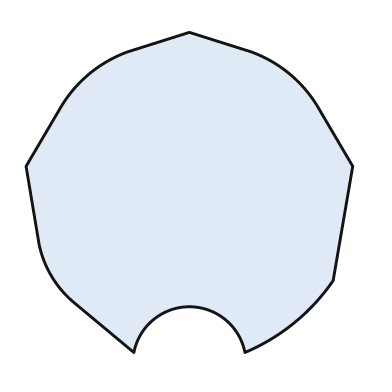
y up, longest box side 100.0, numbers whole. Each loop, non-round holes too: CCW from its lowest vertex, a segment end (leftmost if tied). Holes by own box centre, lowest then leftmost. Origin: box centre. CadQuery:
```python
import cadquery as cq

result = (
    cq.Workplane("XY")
    .moveTo(-17.0, -49.0)
    .threePointArc((0.0, -35.0), (17.0, -49.0))
    .threePointArc((32.0, -40.0), (44.0, -27.0))
    .lineTo(50.0, 8.0)
    .lineTo(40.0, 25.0)
    .threePointArc((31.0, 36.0), (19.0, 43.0))
    .lineTo(0.0, 49.0)
    .lineTo(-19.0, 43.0)
    .threePointArc((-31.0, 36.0), (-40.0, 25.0))
    .lineTo(-50.0, 8.0)
    .lineTo(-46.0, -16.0)
    .threePointArc((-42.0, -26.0), (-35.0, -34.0))
    .close()
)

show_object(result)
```